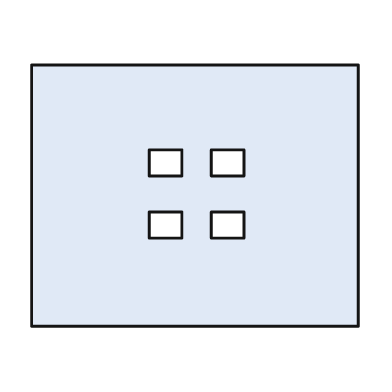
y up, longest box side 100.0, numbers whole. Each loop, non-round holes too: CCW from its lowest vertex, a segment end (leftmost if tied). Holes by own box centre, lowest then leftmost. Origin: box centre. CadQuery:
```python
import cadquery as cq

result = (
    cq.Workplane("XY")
    .moveTo(-50.0, -40.0)
    .lineTo(50.0, -40.0)
    .lineTo(50.0, 40.0)
    .lineTo(-50.0, 40.0)
    .close()
    .moveTo(-14.0, -13.0)
    .lineTo(-4.0, -13.0)
    .lineTo(-4.0, -5.0)
    .lineTo(-14.0, -5.0)
    .close()
    .moveTo(5.0, -13.0)
    .lineTo(15.0, -13.0)
    .lineTo(15.0, -5.0)
    .lineTo(5.0, -5.0)
    .close()
    .moveTo(-14.0, 6.0)
    .lineTo(-4.0, 6.0)
    .lineTo(-4.0, 14.0)
    .lineTo(-14.0, 14.0)
    .close()
    .moveTo(5.0, 6.0)
    .lineTo(15.0, 6.0)
    .lineTo(15.0, 14.0)
    .lineTo(5.0, 14.0)
    .close()
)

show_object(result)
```